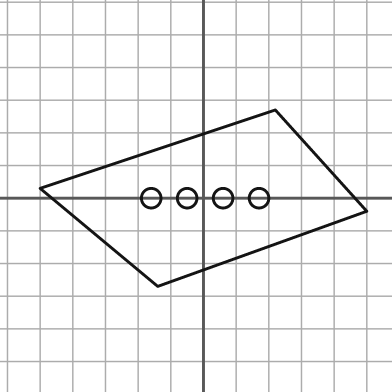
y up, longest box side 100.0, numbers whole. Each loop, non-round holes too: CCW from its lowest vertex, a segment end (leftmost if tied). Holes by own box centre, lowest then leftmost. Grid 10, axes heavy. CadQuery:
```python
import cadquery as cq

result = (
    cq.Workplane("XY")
    .moveTo(-14.0, -27.0)
    .lineTo(50.0, -4.0)
    .lineTo(22.0, 27.0)
    .lineTo(-50.0, 3.0)
    .close()
    .moveTo(-16.0, 0.0)
    .circle(3.0)
    .moveTo(-5.0, 0.0)
    .circle(3.0)
    .moveTo(6.0, 0.0)
    .circle(3.0)
    .moveTo(17.0, 0.0)
    .circle(3.0)
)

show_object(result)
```